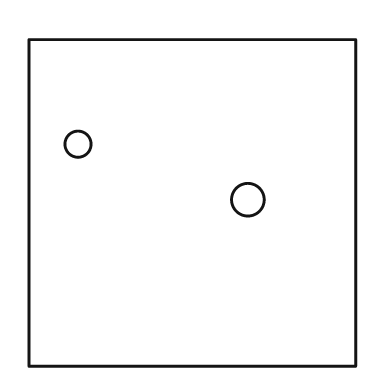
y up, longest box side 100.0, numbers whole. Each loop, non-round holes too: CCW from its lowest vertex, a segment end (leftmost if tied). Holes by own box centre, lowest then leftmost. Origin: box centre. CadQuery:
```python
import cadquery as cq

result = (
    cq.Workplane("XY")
    .moveTo(-50.0, -50.0)
    .lineTo(50.0, -50.0)
    .lineTo(50.0, 50.0)
    .lineTo(-50.0, 50.0)
    .close()
    .moveTo(17.0, 1.0)
    .circle(5.0)
    .moveTo(-35.0, 18.0)
    .circle(4.0)
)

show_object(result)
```